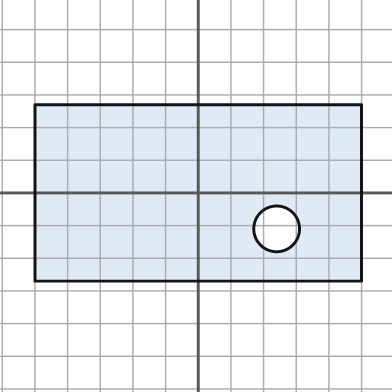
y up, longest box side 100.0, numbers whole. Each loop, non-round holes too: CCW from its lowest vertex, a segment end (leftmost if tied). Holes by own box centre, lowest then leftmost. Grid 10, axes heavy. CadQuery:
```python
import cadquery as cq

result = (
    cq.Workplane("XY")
    .moveTo(-50.0, -27.0)
    .lineTo(50.0, -27.0)
    .lineTo(50.0, 27.0)
    .lineTo(-50.0, 27.0)
    .close()
    .moveTo(24.0, -11.0)
    .circle(7.0)
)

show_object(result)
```